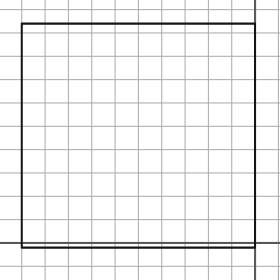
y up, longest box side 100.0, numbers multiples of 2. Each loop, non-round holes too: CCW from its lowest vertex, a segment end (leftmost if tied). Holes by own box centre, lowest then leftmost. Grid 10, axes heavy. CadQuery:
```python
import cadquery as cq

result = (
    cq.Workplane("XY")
    .moveTo(-100.0, -2.0)
    .lineTo(0.0, -2.0)
    .lineTo(0.0, 94.0)
    .lineTo(-100.0, 94.0)
    .close()
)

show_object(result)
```